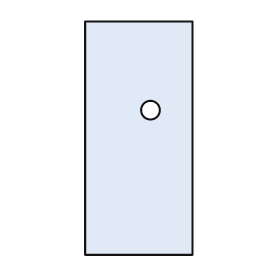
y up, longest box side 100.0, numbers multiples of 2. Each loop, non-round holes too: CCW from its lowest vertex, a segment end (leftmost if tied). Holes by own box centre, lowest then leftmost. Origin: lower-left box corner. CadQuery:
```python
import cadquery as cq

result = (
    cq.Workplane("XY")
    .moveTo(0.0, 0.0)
    .lineTo(46.0, 0.0)
    .lineTo(46.0, 100.0)
    .lineTo(0.0, 100.0)
    .close()
    .moveTo(28.0, 62.0)
    .circle(4.0)
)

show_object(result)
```